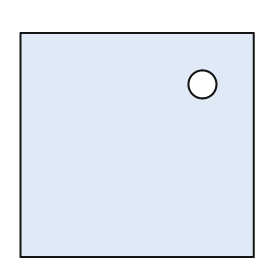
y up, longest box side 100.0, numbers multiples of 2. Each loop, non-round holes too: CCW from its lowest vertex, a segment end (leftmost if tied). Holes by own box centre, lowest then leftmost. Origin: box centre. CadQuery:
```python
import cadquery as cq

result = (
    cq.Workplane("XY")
    .moveTo(-50.0, -48.0)
    .lineTo(50.0, -48.0)
    .lineTo(50.0, 48.0)
    .lineTo(-50.0, 48.0)
    .close()
    .moveTo(28.0, 26.0)
    .circle(6.0)
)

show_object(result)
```